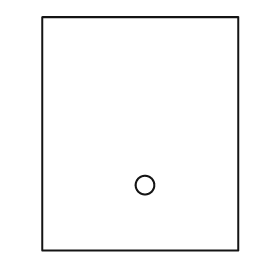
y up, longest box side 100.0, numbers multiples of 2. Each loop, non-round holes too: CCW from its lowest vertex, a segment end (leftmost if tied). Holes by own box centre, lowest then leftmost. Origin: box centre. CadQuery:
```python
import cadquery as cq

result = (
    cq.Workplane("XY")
    .moveTo(-42.0, -50.0)
    .lineTo(42.0, -50.0)
    .lineTo(42.0, 50.0)
    .lineTo(-42.0, 50.0)
    .close()
    .moveTo(2.0, -22.0)
    .circle(4.0)
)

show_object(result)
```